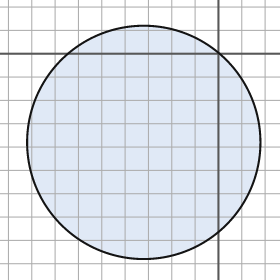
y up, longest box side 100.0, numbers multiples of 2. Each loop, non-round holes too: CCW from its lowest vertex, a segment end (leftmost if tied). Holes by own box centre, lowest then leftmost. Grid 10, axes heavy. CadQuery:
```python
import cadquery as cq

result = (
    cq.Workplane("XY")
    .moveTo(-32.0, -38.0)
    .circle(50.0)
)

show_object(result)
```